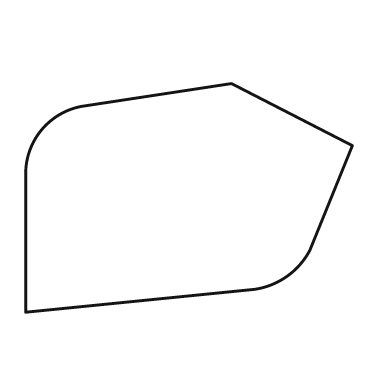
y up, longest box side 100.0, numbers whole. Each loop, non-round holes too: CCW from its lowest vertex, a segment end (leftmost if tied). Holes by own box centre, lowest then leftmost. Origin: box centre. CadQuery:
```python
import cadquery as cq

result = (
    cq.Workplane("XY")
    .moveTo(-50.0, -35.0)
    .lineTo(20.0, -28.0)
    .threePointArc((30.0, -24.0), (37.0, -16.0))
    .lineTo(50.0, 16.0)
    .lineTo(13.0, 35.0)
    .lineTo(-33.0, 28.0)
    .threePointArc((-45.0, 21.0), (-50.0, 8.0))
    .close()
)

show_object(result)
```